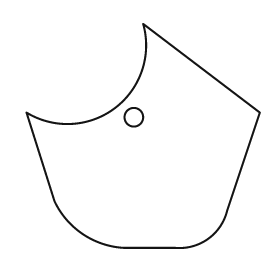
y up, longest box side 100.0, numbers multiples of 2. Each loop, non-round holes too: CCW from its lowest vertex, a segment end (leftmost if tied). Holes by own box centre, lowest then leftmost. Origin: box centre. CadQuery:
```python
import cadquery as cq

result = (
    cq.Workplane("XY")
    .moveTo(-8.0, -48.0)
    .lineTo(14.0, -48.0)
    .threePointArc((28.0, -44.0), (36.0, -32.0))
    .lineTo(50.0, 10.0)
    .lineTo(0.0, 48.0)
    .threePointArc((-12.0, 12.0), (-50.0, 10.0))
    .lineTo(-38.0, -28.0)
    .threePointArc((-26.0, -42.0), (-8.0, -48.0))
    .close()
    .moveTo(-4.0, 8.0)
    .circle(4.0)
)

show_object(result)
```